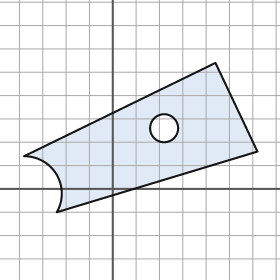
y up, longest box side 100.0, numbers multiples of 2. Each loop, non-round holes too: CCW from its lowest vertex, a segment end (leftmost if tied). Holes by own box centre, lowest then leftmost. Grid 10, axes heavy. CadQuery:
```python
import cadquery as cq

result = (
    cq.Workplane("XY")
    .moveTo(-24.0, -10.0)
    .lineTo(62.0, 16.0)
    .lineTo(44.0, 54.0)
    .lineTo(-38.0, 14.0)
    .threePointArc((-24.0, 6.0), (-24.0, -10.0))
    .close()
    .moveTo(22.0, 26.0)
    .circle(6.0)
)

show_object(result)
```